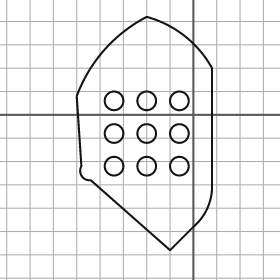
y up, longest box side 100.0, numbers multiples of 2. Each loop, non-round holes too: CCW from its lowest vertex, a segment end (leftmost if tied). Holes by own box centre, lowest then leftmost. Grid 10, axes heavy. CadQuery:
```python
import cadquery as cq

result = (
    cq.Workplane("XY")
    .moveTo(-10.0, -58.0)
    .lineTo(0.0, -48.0)
    .threePointArc((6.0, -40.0), (8.0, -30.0))
    .lineTo(8.0, 20.0)
    .threePointArc((-4.0, 34.0), (-20.0, 42.0))
    .threePointArc((-38.0, 28.0), (-50.0, 8.0))
    .lineTo(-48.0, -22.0)
    .threePointArc((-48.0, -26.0), (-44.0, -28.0))
    .close()
    .moveTo(-34.0, -22.0)
    .circle(4.0)
    .moveTo(-20.0, -22.0)
    .circle(4.0)
    .moveTo(-6.0, -22.0)
    .circle(4.0)
    .moveTo(-34.0, -8.0)
    .circle(4.0)
    .moveTo(-20.0, -8.0)
    .circle(4.0)
    .moveTo(-6.0, -8.0)
    .circle(4.0)
    .moveTo(-34.0, 6.0)
    .circle(4.0)
    .moveTo(-20.0, 6.0)
    .circle(4.0)
    .moveTo(-6.0, 6.0)
    .circle(4.0)
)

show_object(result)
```